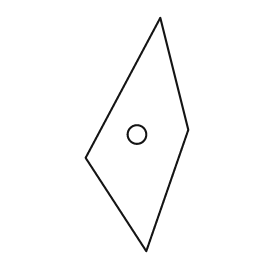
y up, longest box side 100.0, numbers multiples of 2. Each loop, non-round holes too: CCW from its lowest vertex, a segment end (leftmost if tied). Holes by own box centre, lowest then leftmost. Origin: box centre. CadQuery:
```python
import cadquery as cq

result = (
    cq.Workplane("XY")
    .moveTo(4.0, -50.0)
    .lineTo(22.0, 2.0)
    .lineTo(10.0, 50.0)
    .lineTo(-22.0, -10.0)
    .close()
    .moveTo(0.0, 0.0)
    .circle(4.0)
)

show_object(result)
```